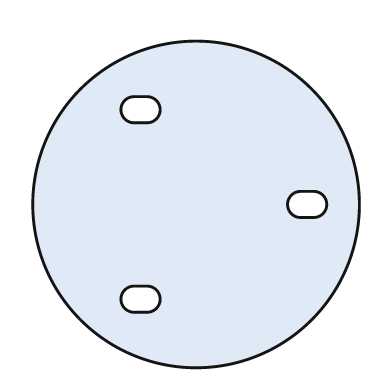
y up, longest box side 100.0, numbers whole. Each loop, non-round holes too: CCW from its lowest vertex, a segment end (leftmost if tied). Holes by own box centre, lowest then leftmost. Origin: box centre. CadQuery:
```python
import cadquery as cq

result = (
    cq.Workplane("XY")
    .moveTo(0.0, 0.0)
    .circle(50.0)
    .moveTo(-19.0, -33.0)
    .lineTo(-15.0, -33.0)
    .threePointArc((-11.0, -29.0), (-15.0, -25.0))
    .lineTo(-19.0, -25.0)
    .threePointArc((-23.0, -29.0), (-19.0, -33.0))
    .close()
    .moveTo(32.0, -4.0)
    .lineTo(36.0, -4.0)
    .threePointArc((40.0, 0.0), (36.0, 4.0))
    .lineTo(32.0, 4.0)
    .threePointArc((28.0, 0.0), (32.0, -4.0))
    .close()
    .moveTo(-19.0, 25.0)
    .lineTo(-15.0, 25.0)
    .threePointArc((-11.0, 29.0), (-15.0, 33.0))
    .lineTo(-19.0, 33.0)
    .threePointArc((-23.0, 29.0), (-19.0, 25.0))
    .close()
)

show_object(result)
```